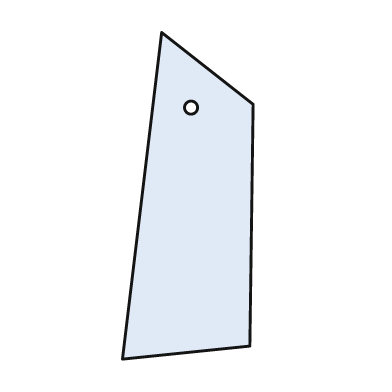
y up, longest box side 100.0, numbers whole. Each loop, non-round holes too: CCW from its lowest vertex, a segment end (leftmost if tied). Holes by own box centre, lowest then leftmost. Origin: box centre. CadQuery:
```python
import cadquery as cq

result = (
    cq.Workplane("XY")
    .moveTo(-20.0, -50.0)
    .lineTo(19.0, -46.0)
    .lineTo(20.0, 28.0)
    .lineTo(-8.0, 50.0)
    .close()
    .moveTo(1.0, 27.0)
    .circle(2.0)
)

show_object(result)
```